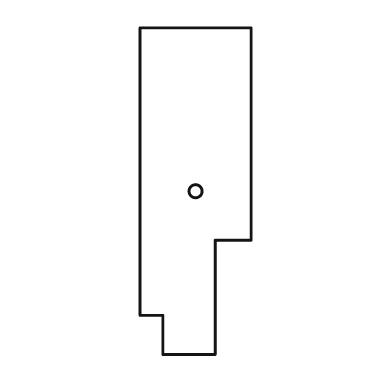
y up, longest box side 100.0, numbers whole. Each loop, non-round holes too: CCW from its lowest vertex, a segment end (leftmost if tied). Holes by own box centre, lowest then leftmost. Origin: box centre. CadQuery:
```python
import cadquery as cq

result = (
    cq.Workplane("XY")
    .moveTo(-10.0, -50.0)
    .lineTo(6.0, -50.0)
    .lineTo(6.0, -15.0)
    .lineTo(17.0, -15.0)
    .lineTo(17.0, 50.0)
    .lineTo(-17.0, 50.0)
    .lineTo(-17.0, -38.0)
    .lineTo(-10.0, -38.0)
    .close()
    .moveTo(0.0, 0.0)
    .circle(2.0)
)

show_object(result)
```